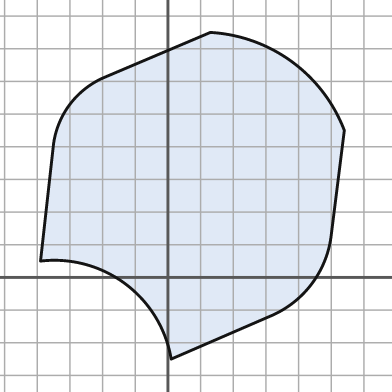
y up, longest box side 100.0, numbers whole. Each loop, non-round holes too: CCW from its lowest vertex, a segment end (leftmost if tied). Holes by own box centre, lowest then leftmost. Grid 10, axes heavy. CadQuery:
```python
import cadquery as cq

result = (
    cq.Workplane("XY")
    .moveTo(1.0, -25.0)
    .lineTo(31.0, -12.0)
    .threePointArc((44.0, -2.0), (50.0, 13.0))
    .lineTo(54.0, 45.0)
    .threePointArc((38.0, 66.0), (13.0, 75.0))
    .lineTo(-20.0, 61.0)
    .threePointArc((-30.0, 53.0), (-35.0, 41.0))
    .lineTo(-39.0, 5.0)
    .threePointArc((-13.0, -2.0), (1.0, -25.0))
    .close()
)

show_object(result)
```